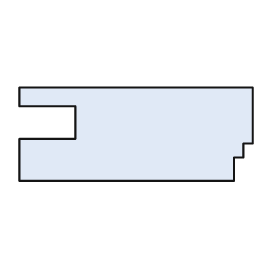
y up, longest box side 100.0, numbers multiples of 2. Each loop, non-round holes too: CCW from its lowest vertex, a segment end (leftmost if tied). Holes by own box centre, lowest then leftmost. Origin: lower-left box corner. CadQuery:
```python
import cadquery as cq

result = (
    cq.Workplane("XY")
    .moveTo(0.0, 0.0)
    .lineTo(92.0, 0.0)
    .lineTo(92.0, 10.0)
    .lineTo(96.0, 10.0)
    .lineTo(96.0, 16.0)
    .lineTo(100.0, 16.0)
    .lineTo(100.0, 40.0)
    .lineTo(0.0, 40.0)
    .lineTo(0.0, 32.0)
    .lineTo(24.0, 32.0)
    .lineTo(24.0, 18.0)
    .lineTo(0.0, 18.0)
    .close()
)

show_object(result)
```